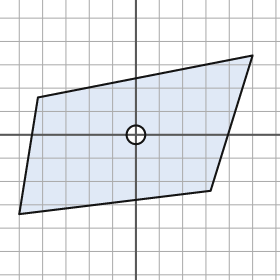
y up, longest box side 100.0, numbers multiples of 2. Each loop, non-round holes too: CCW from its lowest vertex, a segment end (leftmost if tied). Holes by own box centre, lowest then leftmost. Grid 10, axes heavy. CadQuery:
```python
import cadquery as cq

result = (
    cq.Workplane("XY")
    .moveTo(-50.0, -34.0)
    .lineTo(32.0, -24.0)
    .lineTo(50.0, 34.0)
    .lineTo(-42.0, 16.0)
    .close()
    .moveTo(0.0, 0.0)
    .circle(4.0)
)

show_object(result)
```